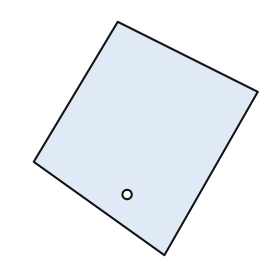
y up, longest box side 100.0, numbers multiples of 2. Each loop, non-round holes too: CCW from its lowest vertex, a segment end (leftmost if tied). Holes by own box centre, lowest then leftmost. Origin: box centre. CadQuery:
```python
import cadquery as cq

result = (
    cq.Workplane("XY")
    .moveTo(8.0, -50.0)
    .lineTo(48.0, 20.0)
    .lineTo(-12.0, 50.0)
    .lineTo(-48.0, -10.0)
    .close()
    .moveTo(-8.0, -24.0)
    .circle(2.0)
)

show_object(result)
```